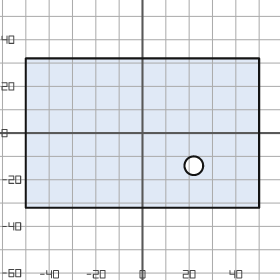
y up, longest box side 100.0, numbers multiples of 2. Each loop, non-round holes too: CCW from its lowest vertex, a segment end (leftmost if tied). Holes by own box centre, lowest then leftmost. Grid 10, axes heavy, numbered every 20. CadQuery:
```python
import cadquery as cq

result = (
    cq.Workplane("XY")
    .moveTo(-50.0, -32.0)
    .lineTo(50.0, -32.0)
    .lineTo(50.0, 32.0)
    .lineTo(-50.0, 32.0)
    .close()
    .moveTo(22.0, -14.0)
    .circle(4.0)
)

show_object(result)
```